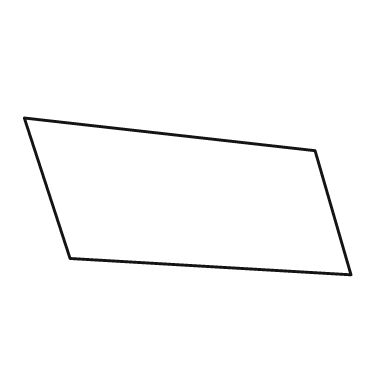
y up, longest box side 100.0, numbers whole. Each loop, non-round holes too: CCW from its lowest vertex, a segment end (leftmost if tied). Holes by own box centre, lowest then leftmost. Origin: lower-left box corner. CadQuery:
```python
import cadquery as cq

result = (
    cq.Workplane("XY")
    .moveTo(100.0, 0.0)
    .lineTo(89.0, 38.0)
    .lineTo(0.0, 48.0)
    .lineTo(14.0, 5.0)
    .close()
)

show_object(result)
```